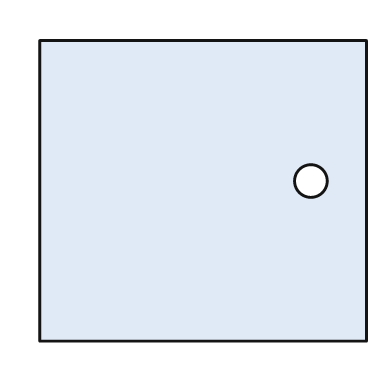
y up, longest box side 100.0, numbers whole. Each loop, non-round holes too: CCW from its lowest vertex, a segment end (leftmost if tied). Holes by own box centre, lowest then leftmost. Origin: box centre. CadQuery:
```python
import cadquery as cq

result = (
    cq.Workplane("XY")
    .moveTo(-50.0, -46.0)
    .lineTo(50.0, -46.0)
    .lineTo(50.0, 46.0)
    .lineTo(-50.0, 46.0)
    .close()
    .moveTo(33.0, 3.0)
    .circle(5.0)
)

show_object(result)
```